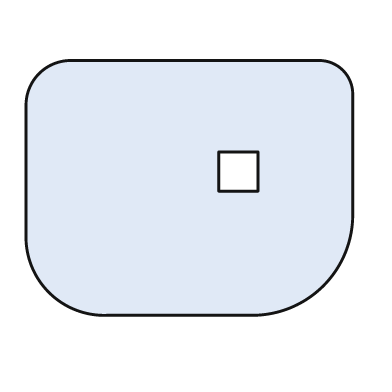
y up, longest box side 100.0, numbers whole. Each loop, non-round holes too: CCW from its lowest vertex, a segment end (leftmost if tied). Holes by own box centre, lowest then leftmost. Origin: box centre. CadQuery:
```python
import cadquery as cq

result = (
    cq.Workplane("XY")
    .moveTo(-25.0, -39.0)
    .lineTo(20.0, -39.0)
    .threePointArc((41.0, -30.0), (50.0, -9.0))
    .lineTo(50.0, 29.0)
    .threePointArc((47.0, 36.0), (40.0, 39.0))
    .lineTo(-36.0, 39.0)
    .threePointArc((-46.0, 35.0), (-50.0, 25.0))
    .lineTo(-50.0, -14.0)
    .threePointArc((-43.0, -32.0), (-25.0, -39.0))
    .close()
    .moveTo(9.0, -1.0)
    .lineTo(21.0, -1.0)
    .lineTo(21.0, 11.0)
    .lineTo(9.0, 11.0)
    .close()
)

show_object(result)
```